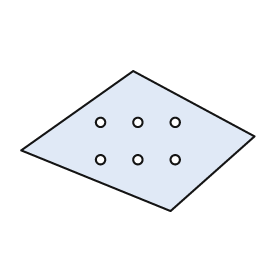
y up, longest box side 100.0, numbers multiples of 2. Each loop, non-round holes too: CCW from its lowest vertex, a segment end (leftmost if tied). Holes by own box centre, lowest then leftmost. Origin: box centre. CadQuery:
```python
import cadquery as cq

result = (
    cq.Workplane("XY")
    .moveTo(14.0, -30.0)
    .lineTo(50.0, 2.0)
    .lineTo(-2.0, 30.0)
    .lineTo(-50.0, -4.0)
    .close()
    .moveTo(-16.0, -8.0)
    .circle(2.0)
    .moveTo(0.0, -8.0)
    .circle(2.0)
    .moveTo(16.0, -8.0)
    .circle(2.0)
    .moveTo(-16.0, 8.0)
    .circle(2.0)
    .moveTo(0.0, 8.0)
    .circle(2.0)
    .moveTo(16.0, 8.0)
    .circle(2.0)
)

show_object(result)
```